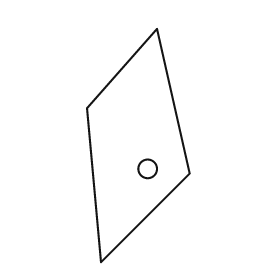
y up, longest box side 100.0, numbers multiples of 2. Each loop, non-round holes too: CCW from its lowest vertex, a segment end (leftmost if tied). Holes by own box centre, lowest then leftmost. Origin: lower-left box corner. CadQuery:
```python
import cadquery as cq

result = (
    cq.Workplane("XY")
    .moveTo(6.0, 0.0)
    .lineTo(44.0, 38.0)
    .lineTo(30.0, 100.0)
    .lineTo(0.0, 66.0)
    .close()
    .moveTo(26.0, 40.0)
    .circle(4.0)
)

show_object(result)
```